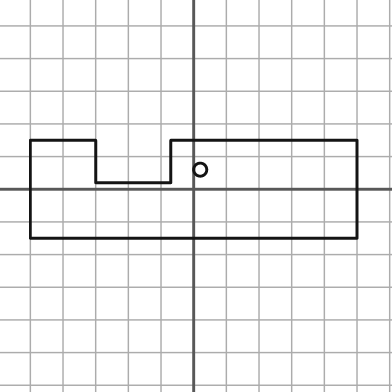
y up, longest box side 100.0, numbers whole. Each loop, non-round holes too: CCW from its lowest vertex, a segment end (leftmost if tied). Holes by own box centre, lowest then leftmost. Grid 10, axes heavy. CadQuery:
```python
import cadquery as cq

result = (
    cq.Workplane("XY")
    .moveTo(-50.0, -15.0)
    .lineTo(50.0, -15.0)
    .lineTo(50.0, 15.0)
    .lineTo(-7.0, 15.0)
    .lineTo(-7.0, 2.0)
    .lineTo(-30.0, 2.0)
    .lineTo(-30.0, 15.0)
    .lineTo(-50.0, 15.0)
    .close()
    .moveTo(2.0, 6.0)
    .circle(2.0)
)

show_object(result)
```